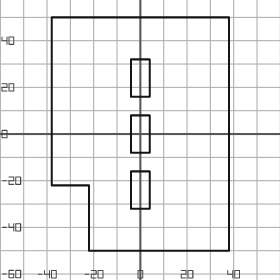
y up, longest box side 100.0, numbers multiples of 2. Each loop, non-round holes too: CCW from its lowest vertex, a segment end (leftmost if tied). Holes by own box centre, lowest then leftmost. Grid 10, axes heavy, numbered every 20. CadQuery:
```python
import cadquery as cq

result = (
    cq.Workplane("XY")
    .moveTo(-22.0, -50.0)
    .lineTo(38.0, -50.0)
    .lineTo(38.0, 50.0)
    .lineTo(-38.0, 50.0)
    .lineTo(-38.0, -22.0)
    .lineTo(-22.0, -22.0)
    .close()
    .moveTo(-4.0, -32.0)
    .lineTo(4.0, -32.0)
    .lineTo(4.0, -16.0)
    .lineTo(-4.0, -16.0)
    .close()
    .moveTo(-4.0, -8.0)
    .lineTo(4.0, -8.0)
    .lineTo(4.0, 8.0)
    .lineTo(-4.0, 8.0)
    .close()
    .moveTo(-4.0, 16.0)
    .lineTo(4.0, 16.0)
    .lineTo(4.0, 32.0)
    .lineTo(-4.0, 32.0)
    .close()
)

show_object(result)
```